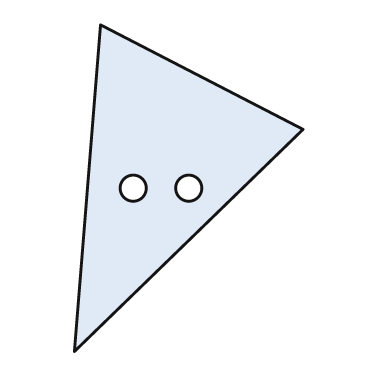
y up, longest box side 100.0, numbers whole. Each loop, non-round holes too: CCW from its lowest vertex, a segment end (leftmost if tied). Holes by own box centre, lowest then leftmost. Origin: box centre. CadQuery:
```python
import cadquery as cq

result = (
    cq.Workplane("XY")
    .moveTo(-35.0, -50.0)
    .lineTo(35.0, 18.0)
    .lineTo(-27.0, 50.0)
    .close()
    .moveTo(-17.0, 0.0)
    .circle(4.0)
    .moveTo(0.0, 0.0)
    .circle(4.0)
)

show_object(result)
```